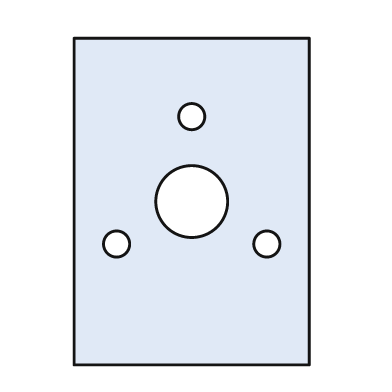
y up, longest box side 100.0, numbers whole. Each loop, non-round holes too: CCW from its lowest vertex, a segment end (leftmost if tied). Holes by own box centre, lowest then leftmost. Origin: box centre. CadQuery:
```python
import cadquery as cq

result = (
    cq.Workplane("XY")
    .moveTo(-36.0, -50.0)
    .lineTo(36.0, -50.0)
    .lineTo(36.0, 50.0)
    .lineTo(-36.0, 50.0)
    .close()
    .moveTo(-23.0, -13.0)
    .circle(4.0)
    .moveTo(23.0, -13.0)
    .circle(4.0)
    .moveTo(0.0, 0.0)
    .circle(11.0)
    .moveTo(0.0, 26.0)
    .circle(4.0)
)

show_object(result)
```